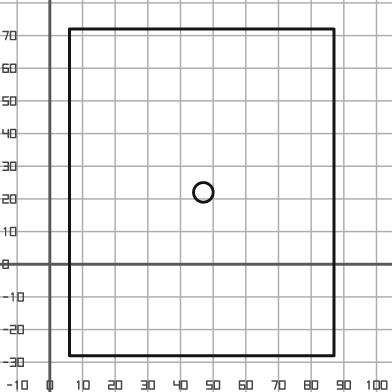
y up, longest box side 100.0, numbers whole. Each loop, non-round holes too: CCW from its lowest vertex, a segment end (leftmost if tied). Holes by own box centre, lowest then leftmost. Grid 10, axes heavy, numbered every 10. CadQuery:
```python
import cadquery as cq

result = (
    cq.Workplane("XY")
    .moveTo(6.0, -28.0)
    .lineTo(87.0, -28.0)
    .lineTo(87.0, 72.0)
    .lineTo(6.0, 72.0)
    .close()
    .moveTo(47.0, 22.0)
    .circle(3.0)
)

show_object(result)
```